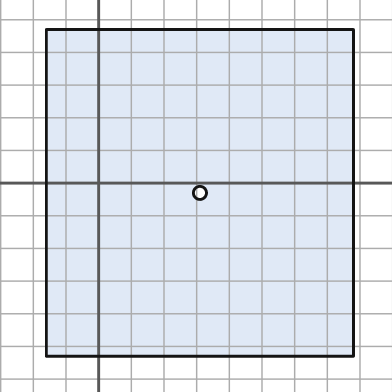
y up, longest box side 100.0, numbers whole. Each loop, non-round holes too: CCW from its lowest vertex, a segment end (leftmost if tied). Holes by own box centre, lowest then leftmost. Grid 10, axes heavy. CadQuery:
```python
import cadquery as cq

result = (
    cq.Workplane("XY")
    .moveTo(-16.0, -53.0)
    .lineTo(78.0, -53.0)
    .lineTo(78.0, 47.0)
    .lineTo(-16.0, 47.0)
    .close()
    .moveTo(31.0, -3.0)
    .circle(2.0)
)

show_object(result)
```